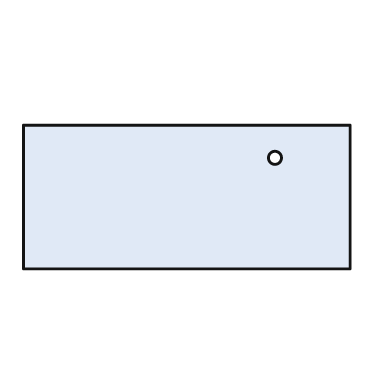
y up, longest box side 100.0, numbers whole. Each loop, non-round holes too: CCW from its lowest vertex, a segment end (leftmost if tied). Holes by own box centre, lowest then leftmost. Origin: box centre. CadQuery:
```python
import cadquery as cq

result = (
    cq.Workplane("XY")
    .moveTo(-50.0, -22.0)
    .lineTo(50.0, -22.0)
    .lineTo(50.0, 22.0)
    .lineTo(-50.0, 22.0)
    .close()
    .moveTo(27.0, 12.0)
    .circle(2.0)
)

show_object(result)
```